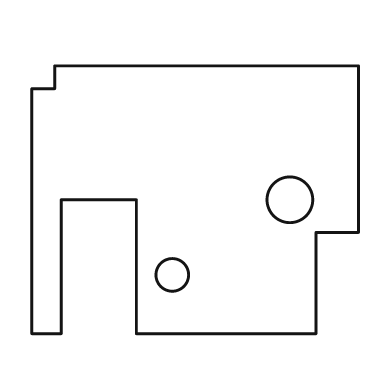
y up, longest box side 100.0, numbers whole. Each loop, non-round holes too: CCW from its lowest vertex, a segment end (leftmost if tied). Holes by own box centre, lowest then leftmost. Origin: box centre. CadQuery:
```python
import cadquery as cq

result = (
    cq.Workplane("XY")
    .moveTo(-50.0, -41.0)
    .lineTo(-41.0, -41.0)
    .lineTo(-41.0, 0.0)
    .lineTo(-18.0, 0.0)
    .lineTo(-18.0, -41.0)
    .lineTo(37.0, -41.0)
    .lineTo(37.0, -10.0)
    .lineTo(50.0, -10.0)
    .lineTo(50.0, 41.0)
    .lineTo(-43.0, 41.0)
    .lineTo(-43.0, 34.0)
    .lineTo(-50.0, 34.0)
    .close()
    .moveTo(-7.0, -23.0)
    .circle(5.0)
    .moveTo(29.0, 0.0)
    .circle(7.0)
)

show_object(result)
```